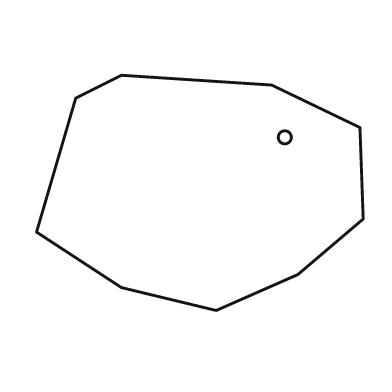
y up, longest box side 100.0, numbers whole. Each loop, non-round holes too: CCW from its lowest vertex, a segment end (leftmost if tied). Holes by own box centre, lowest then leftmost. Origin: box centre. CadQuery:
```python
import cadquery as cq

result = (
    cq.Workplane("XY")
    .moveTo(5.0, -36.0)
    .lineTo(30.0, -25.0)
    .lineTo(50.0, -8.0)
    .lineTo(49.0, 20.0)
    .lineTo(22.0, 33.0)
    .lineTo(-24.0, 36.0)
    .lineTo(-38.0, 29.0)
    .lineTo(-50.0, -12.0)
    .lineTo(-24.0, -29.0)
    .close()
    .moveTo(26.0, 17.0)
    .circle(2.0)
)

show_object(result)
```